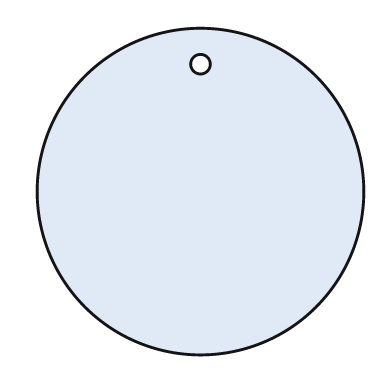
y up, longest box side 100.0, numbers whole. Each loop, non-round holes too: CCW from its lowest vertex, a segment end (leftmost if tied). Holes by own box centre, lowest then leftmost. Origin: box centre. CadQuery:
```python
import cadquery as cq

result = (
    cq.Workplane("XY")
    .moveTo(0.0, 0.0)
    .circle(50.0)
    .moveTo(0.0, 39.0)
    .circle(3.0)
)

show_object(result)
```